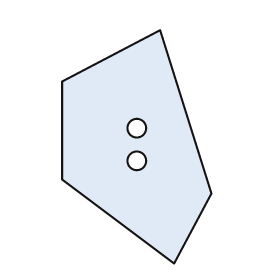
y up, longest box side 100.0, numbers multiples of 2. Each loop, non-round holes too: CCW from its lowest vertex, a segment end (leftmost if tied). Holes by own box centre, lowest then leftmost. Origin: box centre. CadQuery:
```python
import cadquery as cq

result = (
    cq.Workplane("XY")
    .moveTo(16.0, -50.0)
    .lineTo(32.0, -20.0)
    .lineTo(10.0, 50.0)
    .lineTo(-32.0, 28.0)
    .lineTo(-32.0, -14.0)
    .close()
    .moveTo(0.0, -6.0)
    .circle(4.0)
    .moveTo(0.0, 8.0)
    .circle(4.0)
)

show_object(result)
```